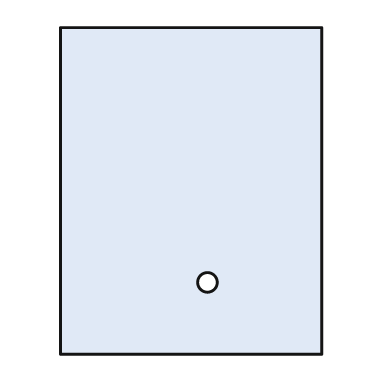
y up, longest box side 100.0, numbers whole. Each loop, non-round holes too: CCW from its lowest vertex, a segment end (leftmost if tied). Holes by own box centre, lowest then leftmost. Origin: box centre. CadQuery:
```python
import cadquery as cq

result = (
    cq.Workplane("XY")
    .moveTo(-40.0, -50.0)
    .lineTo(40.0, -50.0)
    .lineTo(40.0, 50.0)
    .lineTo(-40.0, 50.0)
    .close()
    .moveTo(5.0, -28.0)
    .circle(3.0)
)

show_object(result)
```